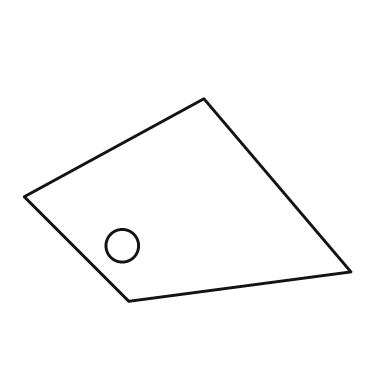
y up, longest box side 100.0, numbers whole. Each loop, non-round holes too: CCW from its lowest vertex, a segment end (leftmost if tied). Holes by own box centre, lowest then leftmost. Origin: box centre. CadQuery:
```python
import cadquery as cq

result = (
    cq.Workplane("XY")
    .moveTo(-18.0, -31.0)
    .lineTo(50.0, -22.0)
    .lineTo(5.0, 31.0)
    .lineTo(-50.0, 1.0)
    .close()
    .moveTo(-20.0, -14.0)
    .circle(5.0)
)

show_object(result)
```